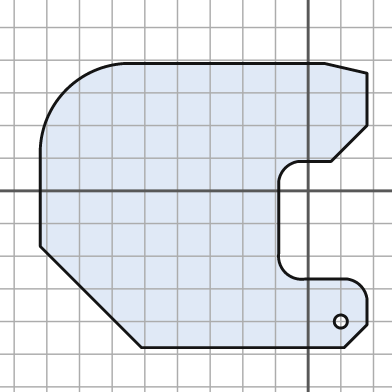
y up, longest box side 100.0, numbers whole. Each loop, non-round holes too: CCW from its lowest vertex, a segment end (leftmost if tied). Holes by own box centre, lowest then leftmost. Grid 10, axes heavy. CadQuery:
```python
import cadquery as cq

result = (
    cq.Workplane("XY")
    .moveTo(-51.0, -48.0)
    .lineTo(11.0, -48.0)
    .lineTo(18.0, -41.0)
    .lineTo(18.0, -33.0)
    .threePointArc((16.0, -29.0), (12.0, -27.0))
    .lineTo(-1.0, -27.0)
    .threePointArc((-7.0, -25.0), (-9.0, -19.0))
    .lineTo(-9.0, 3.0)
    .threePointArc((-7.0, 7.0), (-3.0, 9.0))
    .lineTo(7.0, 9.0)
    .lineTo(18.0, 20.0)
    .lineTo(18.0, 36.0)
    .lineTo(5.0, 39.0)
    .lineTo(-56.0, 39.0)
    .threePointArc((-74.0, 31.0), (-82.0, 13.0))
    .lineTo(-82.0, -17.0)
    .close()
    .moveTo(10.0, -40.0)
    .circle(2.0)
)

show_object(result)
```